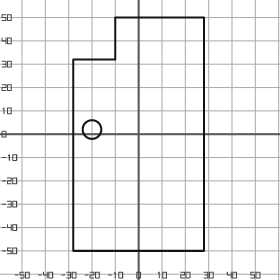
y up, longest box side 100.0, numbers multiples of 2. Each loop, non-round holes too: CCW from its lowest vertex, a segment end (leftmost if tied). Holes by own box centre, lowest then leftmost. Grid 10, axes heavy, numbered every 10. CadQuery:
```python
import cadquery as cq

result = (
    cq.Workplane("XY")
    .moveTo(-28.0, -50.0)
    .lineTo(28.0, -50.0)
    .lineTo(28.0, 50.0)
    .lineTo(-10.0, 50.0)
    .lineTo(-10.0, 32.0)
    .lineTo(-28.0, 32.0)
    .close()
    .moveTo(-20.0, 2.0)
    .circle(4.0)
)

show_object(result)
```